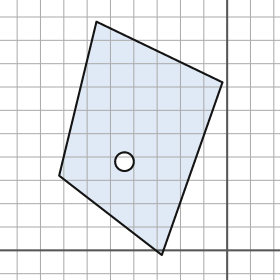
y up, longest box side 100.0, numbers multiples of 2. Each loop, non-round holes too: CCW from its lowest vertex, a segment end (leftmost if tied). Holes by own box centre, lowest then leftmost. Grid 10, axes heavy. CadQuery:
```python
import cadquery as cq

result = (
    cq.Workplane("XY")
    .moveTo(-28.0, -2.0)
    .lineTo(-2.0, 72.0)
    .lineTo(-56.0, 98.0)
    .lineTo(-72.0, 32.0)
    .close()
    .moveTo(-44.0, 38.0)
    .circle(4.0)
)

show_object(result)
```